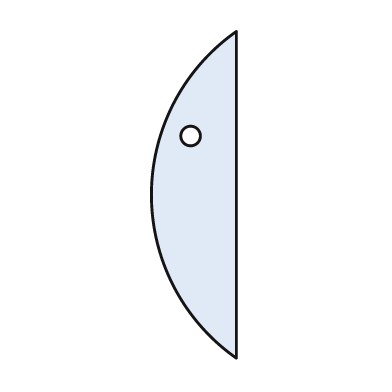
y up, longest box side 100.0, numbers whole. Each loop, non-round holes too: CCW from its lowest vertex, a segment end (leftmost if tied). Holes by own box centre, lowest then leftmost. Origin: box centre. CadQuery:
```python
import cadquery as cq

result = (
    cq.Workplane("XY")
    .moveTo(13.0, -50.0)
    .lineTo(13.0, 50.0)
    .threePointArc((-13.0, 0.0), (13.0, -50.0))
    .close()
    .moveTo(-1.0, 18.0)
    .circle(3.0)
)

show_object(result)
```